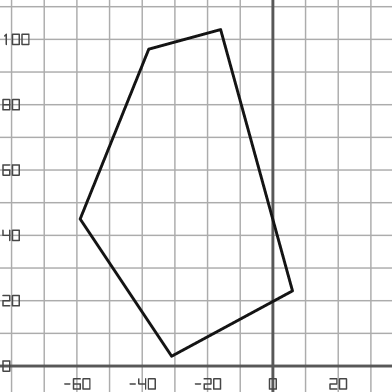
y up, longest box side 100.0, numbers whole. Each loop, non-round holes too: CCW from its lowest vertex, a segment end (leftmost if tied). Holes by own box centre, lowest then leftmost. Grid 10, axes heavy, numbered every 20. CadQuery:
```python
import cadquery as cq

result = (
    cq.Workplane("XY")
    .moveTo(-31.0, 3.0)
    .lineTo(6.0, 23.0)
    .lineTo(-16.0, 103.0)
    .lineTo(-38.0, 97.0)
    .lineTo(-59.0, 45.0)
    .close()
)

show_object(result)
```